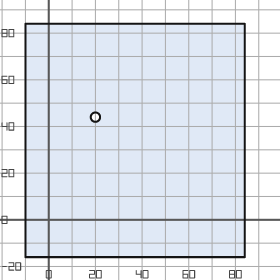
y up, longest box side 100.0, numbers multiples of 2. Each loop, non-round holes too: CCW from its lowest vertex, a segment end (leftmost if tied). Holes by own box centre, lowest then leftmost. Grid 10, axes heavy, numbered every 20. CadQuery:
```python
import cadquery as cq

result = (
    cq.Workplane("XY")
    .moveTo(-10.0, -16.0)
    .lineTo(84.0, -16.0)
    .lineTo(84.0, 84.0)
    .lineTo(-10.0, 84.0)
    .close()
    .moveTo(20.0, 44.0)
    .circle(2.0)
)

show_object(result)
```